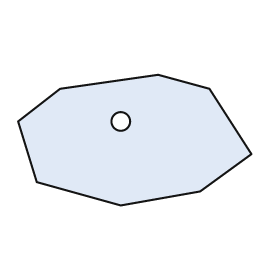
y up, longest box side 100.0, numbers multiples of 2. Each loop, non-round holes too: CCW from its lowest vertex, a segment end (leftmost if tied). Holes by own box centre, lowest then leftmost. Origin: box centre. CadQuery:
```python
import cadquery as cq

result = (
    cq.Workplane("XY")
    .moveTo(-6.0, -28.0)
    .lineTo(28.0, -22.0)
    .lineTo(50.0, -6.0)
    .lineTo(32.0, 22.0)
    .lineTo(10.0, 28.0)
    .lineTo(-32.0, 22.0)
    .lineTo(-50.0, 8.0)
    .lineTo(-42.0, -18.0)
    .close()
    .moveTo(-6.0, 8.0)
    .circle(4.0)
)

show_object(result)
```